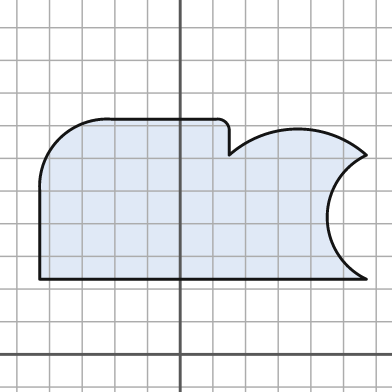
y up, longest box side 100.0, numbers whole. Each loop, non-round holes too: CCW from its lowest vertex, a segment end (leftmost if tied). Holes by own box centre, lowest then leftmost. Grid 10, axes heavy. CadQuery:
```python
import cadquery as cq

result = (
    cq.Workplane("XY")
    .moveTo(-43.0, 23.0)
    .lineTo(57.0, 23.0)
    .threePointArc((45.0, 42.0), (57.0, 61.0))
    .threePointArc((36.0, 69.0), (15.0, 61.0))
    .lineTo(15.0, 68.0)
    .threePointArc((14.0, 71.0), (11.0, 72.0))
    .lineTo(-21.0, 72.0)
    .threePointArc((-37.0, 66.0), (-43.0, 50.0))
    .close()
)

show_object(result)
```